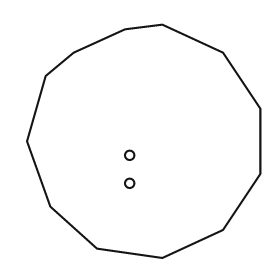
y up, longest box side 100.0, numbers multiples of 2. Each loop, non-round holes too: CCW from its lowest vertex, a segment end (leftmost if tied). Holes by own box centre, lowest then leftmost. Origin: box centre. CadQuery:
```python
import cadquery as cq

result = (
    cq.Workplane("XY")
    .moveTo(8.0, -50.0)
    .lineTo(34.0, -38.0)
    .lineTo(50.0, -14.0)
    .lineTo(50.0, 14.0)
    .lineTo(34.0, 38.0)
    .lineTo(8.0, 50.0)
    .lineTo(-8.0, 48.0)
    .lineTo(-30.0, 38.0)
    .lineTo(-42.0, 28.0)
    .lineTo(-50.0, 0.0)
    .lineTo(-40.0, -28.0)
    .lineTo(-20.0, -46.0)
    .close()
    .moveTo(-6.0, -18.0)
    .circle(2.0)
    .moveTo(-6.0, -6.0)
    .circle(2.0)
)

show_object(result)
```